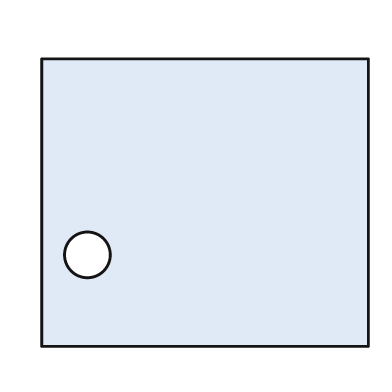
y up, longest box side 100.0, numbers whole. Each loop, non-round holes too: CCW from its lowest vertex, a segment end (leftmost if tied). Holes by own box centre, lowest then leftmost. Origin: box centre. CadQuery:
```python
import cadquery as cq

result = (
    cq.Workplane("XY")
    .moveTo(-50.0, -44.0)
    .lineTo(50.0, -44.0)
    .lineTo(50.0, 44.0)
    .lineTo(-50.0, 44.0)
    .close()
    .moveTo(-36.0, -16.0)
    .circle(7.0)
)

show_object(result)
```